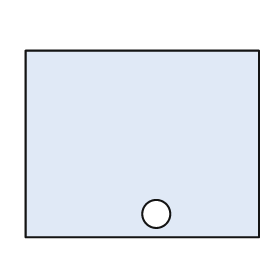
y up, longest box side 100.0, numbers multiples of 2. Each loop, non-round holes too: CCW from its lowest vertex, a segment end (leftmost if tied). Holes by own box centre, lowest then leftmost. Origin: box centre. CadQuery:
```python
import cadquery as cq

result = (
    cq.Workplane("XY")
    .moveTo(-50.0, -40.0)
    .lineTo(50.0, -40.0)
    .lineTo(50.0, 40.0)
    .lineTo(-50.0, 40.0)
    .close()
    .moveTo(6.0, -30.0)
    .circle(6.0)
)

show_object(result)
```